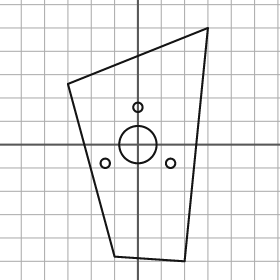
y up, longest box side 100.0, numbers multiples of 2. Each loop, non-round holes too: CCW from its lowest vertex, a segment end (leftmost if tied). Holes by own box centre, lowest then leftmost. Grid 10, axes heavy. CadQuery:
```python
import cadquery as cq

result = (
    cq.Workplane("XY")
    .moveTo(20.0, -50.0)
    .lineTo(30.0, 50.0)
    .lineTo(-30.0, 26.0)
    .lineTo(-10.0, -48.0)
    .close()
    .moveTo(-14.0, -8.0)
    .circle(2.0)
    .moveTo(14.0, -8.0)
    .circle(2.0)
    .moveTo(0.0, 0.0)
    .circle(8.0)
    .moveTo(0.0, 16.0)
    .circle(2.0)
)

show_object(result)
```